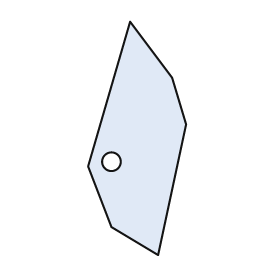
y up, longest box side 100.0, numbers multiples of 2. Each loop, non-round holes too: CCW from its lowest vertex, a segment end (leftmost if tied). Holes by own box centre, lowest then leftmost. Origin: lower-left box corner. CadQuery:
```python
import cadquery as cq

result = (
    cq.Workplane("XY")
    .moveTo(30.0, 0.0)
    .lineTo(42.0, 56.0)
    .lineTo(36.0, 76.0)
    .lineTo(18.0, 100.0)
    .lineTo(0.0, 38.0)
    .lineTo(10.0, 12.0)
    .close()
    .moveTo(10.0, 40.0)
    .circle(4.0)
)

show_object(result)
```